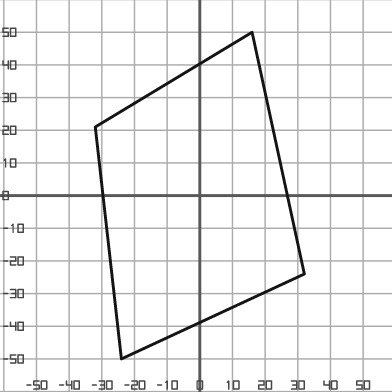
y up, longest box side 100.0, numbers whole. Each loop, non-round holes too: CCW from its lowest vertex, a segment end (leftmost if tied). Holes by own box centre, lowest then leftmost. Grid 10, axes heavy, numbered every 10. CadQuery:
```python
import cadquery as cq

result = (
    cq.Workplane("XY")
    .moveTo(-24.0, -50.0)
    .lineTo(32.0, -24.0)
    .lineTo(16.0, 50.0)
    .lineTo(-32.0, 21.0)
    .close()
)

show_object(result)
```